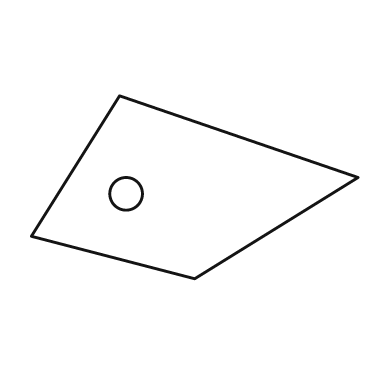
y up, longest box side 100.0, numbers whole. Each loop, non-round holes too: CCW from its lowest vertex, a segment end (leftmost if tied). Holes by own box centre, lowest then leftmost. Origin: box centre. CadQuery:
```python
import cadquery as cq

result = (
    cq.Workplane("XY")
    .moveTo(0.0, -28.0)
    .lineTo(50.0, 3.0)
    .lineTo(-23.0, 28.0)
    .lineTo(-50.0, -15.0)
    .close()
    .moveTo(-21.0, -2.0)
    .circle(5.0)
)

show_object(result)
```